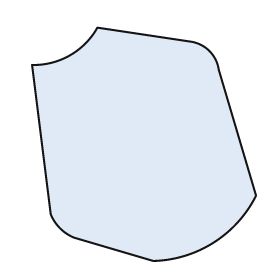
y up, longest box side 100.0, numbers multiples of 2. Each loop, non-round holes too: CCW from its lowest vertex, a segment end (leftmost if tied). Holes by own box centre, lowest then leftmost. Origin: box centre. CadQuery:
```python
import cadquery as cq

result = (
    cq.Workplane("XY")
    .moveTo(4.0, -50.0)
    .threePointArc((30.0, -42.0), (48.0, -22.0))
    .lineTo(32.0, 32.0)
    .threePointArc((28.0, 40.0), (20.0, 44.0))
    .lineTo(-20.0, 50.0)
    .threePointArc((-32.0, 38.0), (-48.0, 34.0))
    .lineTo(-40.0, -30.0)
    .threePointArc((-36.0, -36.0), (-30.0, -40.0))
    .close()
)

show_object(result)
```